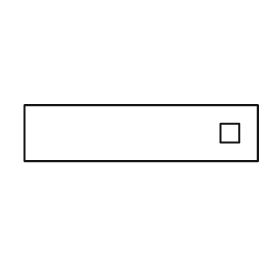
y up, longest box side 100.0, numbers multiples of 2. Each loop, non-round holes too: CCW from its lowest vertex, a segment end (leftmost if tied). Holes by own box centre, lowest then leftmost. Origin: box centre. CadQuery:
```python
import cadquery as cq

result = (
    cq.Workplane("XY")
    .moveTo(-50.0, -12.0)
    .lineTo(50.0, -12.0)
    .lineTo(50.0, 12.0)
    .lineTo(-50.0, 12.0)
    .close()
    .moveTo(34.0, -4.0)
    .lineTo(42.0, -4.0)
    .lineTo(42.0, 4.0)
    .lineTo(34.0, 4.0)
    .close()
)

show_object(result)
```